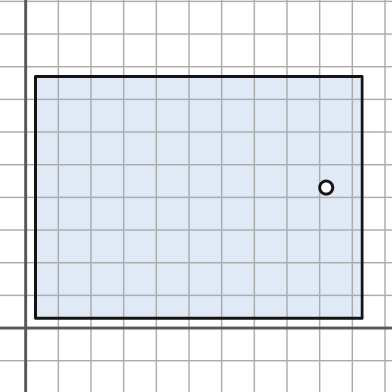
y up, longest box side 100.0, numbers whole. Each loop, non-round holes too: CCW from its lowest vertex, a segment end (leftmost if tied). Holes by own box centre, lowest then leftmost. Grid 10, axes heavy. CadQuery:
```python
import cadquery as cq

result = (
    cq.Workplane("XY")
    .moveTo(3.0, 3.0)
    .lineTo(103.0, 3.0)
    .lineTo(103.0, 77.0)
    .lineTo(3.0, 77.0)
    .close()
    .moveTo(92.0, 43.0)
    .circle(2.0)
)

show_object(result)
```